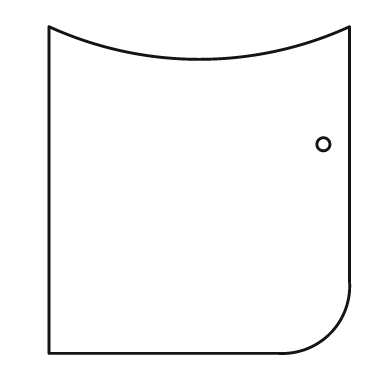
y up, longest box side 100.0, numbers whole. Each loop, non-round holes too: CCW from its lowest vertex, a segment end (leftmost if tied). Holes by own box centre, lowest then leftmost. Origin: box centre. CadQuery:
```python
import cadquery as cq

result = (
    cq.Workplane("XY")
    .moveTo(-46.0, -50.0)
    .lineTo(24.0, -50.0)
    .threePointArc((40.0, -44.0), (46.0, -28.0))
    .lineTo(46.0, 50.0)
    .threePointArc((0.0, 40.0), (-46.0, 50.0))
    .close()
    .moveTo(38.0, 14.0)
    .circle(2.0)
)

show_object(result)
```